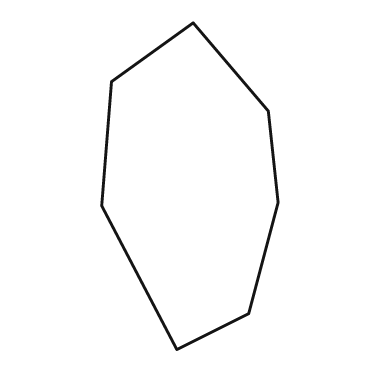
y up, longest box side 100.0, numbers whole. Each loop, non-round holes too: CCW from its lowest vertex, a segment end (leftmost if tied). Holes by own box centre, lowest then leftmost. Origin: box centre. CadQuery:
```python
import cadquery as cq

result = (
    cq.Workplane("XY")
    .moveTo(-4.0, -50.0)
    .lineTo(18.0, -39.0)
    .lineTo(27.0, -5.0)
    .lineTo(24.0, 23.0)
    .lineTo(1.0, 50.0)
    .lineTo(-24.0, 32.0)
    .lineTo(-27.0, -6.0)
    .close()
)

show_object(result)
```